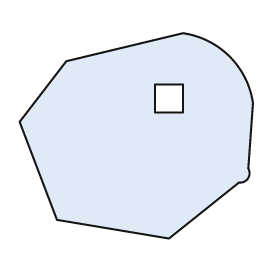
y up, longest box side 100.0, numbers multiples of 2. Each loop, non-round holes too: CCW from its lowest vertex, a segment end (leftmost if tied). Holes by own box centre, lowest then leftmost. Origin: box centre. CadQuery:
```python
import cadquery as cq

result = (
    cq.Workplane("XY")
    .moveTo(14.0, -44.0)
    .lineTo(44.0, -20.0)
    .threePointArc((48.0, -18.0), (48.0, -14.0))
    .lineTo(50.0, 14.0)
    .threePointArc((40.0, 34.0), (20.0, 44.0))
    .lineTo(-30.0, 32.0)
    .lineTo(-50.0, 6.0)
    .lineTo(-34.0, -36.0)
    .close()
    .moveTo(8.0, 10.0)
    .lineTo(20.0, 10.0)
    .lineTo(20.0, 22.0)
    .lineTo(8.0, 22.0)
    .close()
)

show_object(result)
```